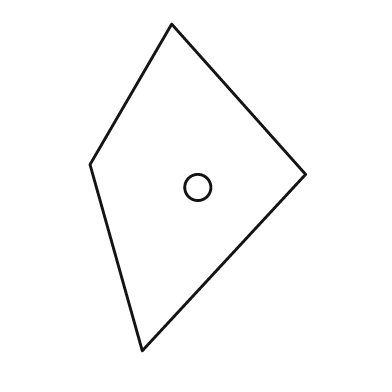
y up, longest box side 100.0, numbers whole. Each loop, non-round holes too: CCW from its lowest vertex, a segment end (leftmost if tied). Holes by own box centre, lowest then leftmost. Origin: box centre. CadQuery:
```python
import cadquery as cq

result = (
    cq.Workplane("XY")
    .moveTo(-17.0, -50.0)
    .lineTo(33.0, 4.0)
    .lineTo(-8.0, 50.0)
    .lineTo(-33.0, 7.0)
    .close()
    .moveTo(0.0, 0.0)
    .circle(4.0)
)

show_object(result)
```